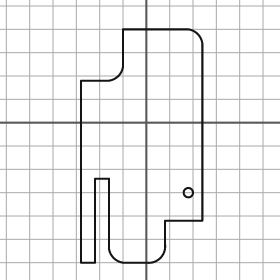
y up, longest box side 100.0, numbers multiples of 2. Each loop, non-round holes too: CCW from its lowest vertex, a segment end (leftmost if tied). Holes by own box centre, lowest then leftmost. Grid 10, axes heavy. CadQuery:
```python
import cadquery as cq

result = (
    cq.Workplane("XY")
    .moveTo(-28.0, -60.0)
    .lineTo(-22.0, -60.0)
    .lineTo(-22.0, -24.0)
    .lineTo(-16.0, -24.0)
    .lineTo(-16.0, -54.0)
    .threePointArc((-14.0, -58.0), (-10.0, -60.0))
    .lineTo(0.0, -60.0)
    .threePointArc((6.0, -58.0), (8.0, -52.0))
    .lineTo(8.0, -42.0)
    .lineTo(24.0, -42.0)
    .lineTo(24.0, 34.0)
    .threePointArc((22.0, 38.0), (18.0, 40.0))
    .lineTo(-10.0, 40.0)
    .lineTo(-10.0, 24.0)
    .threePointArc((-12.0, 20.0), (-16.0, 18.0))
    .lineTo(-28.0, 18.0)
    .close()
    .moveTo(18.0, -30.0)
    .circle(2.0)
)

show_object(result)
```